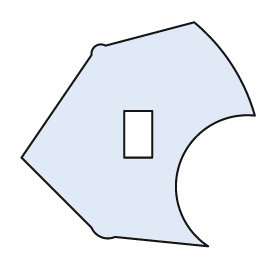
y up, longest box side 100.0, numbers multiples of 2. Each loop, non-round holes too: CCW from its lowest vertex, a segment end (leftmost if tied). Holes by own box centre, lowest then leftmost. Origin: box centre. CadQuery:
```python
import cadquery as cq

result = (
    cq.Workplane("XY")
    .moveTo(30.0, -48.0)
    .threePointArc((18.0, -12.0), (50.0, 8.0))
    .threePointArc((40.0, 30.0), (24.0, 48.0))
    .lineTo(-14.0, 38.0)
    .threePointArc((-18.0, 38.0), (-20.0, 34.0))
    .lineTo(-50.0, -10.0)
    .lineTo(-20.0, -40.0)
    .threePointArc((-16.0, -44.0), (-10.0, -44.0))
    .close()
    .moveTo(-6.0, -10.0)
    .lineTo(6.0, -10.0)
    .lineTo(6.0, 10.0)
    .lineTo(-6.0, 10.0)
    .close()
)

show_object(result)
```